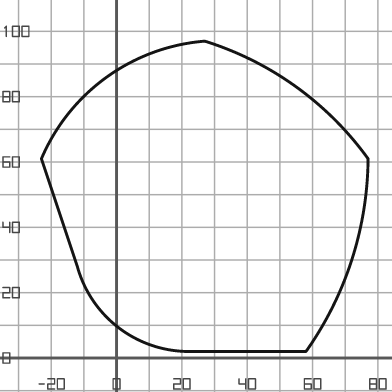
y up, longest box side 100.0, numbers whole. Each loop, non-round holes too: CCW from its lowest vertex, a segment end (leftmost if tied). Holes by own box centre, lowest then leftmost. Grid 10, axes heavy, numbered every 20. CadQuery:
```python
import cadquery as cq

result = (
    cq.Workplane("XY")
    .moveTo(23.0, 2.0)
    .lineTo(58.0, 2.0)
    .threePointArc((72.0, 30.0), (77.0, 61.0))
    .threePointArc((55.0, 83.0), (27.0, 97.0))
    .threePointArc((-3.0, 86.0), (-23.0, 61.0))
    .lineTo(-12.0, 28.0)
    .threePointArc((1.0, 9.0), (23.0, 2.0))
    .close()
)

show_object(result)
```